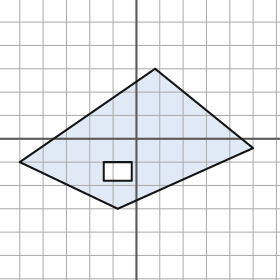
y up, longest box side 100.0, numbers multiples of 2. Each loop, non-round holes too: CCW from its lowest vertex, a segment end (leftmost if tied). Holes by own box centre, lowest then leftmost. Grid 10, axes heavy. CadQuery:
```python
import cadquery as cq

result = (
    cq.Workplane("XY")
    .moveTo(-8.0, -30.0)
    .lineTo(50.0, -4.0)
    .lineTo(8.0, 30.0)
    .lineTo(-50.0, -10.0)
    .close()
    .moveTo(-14.0, -18.0)
    .lineTo(-2.0, -18.0)
    .lineTo(-2.0, -10.0)
    .lineTo(-14.0, -10.0)
    .close()
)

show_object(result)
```